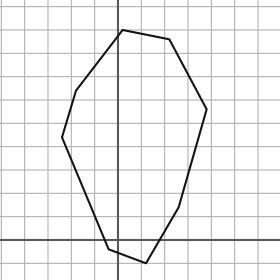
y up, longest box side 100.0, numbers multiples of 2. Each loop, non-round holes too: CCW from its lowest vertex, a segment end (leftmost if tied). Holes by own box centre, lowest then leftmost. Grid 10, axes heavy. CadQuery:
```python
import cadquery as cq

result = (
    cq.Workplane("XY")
    .moveTo(12.0, -10.0)
    .lineTo(26.0, 14.0)
    .lineTo(38.0, 56.0)
    .lineTo(22.0, 86.0)
    .lineTo(2.0, 90.0)
    .lineTo(-18.0, 64.0)
    .lineTo(-24.0, 44.0)
    .lineTo(-4.0, -4.0)
    .close()
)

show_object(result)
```